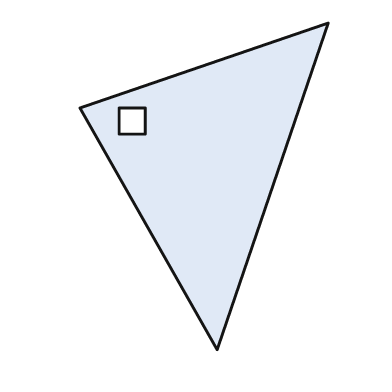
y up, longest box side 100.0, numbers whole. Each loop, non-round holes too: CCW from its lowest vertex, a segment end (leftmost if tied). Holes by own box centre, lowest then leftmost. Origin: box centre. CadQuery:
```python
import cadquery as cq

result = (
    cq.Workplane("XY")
    .moveTo(4.0, -50.0)
    .lineTo(38.0, 50.0)
    .lineTo(-38.0, 24.0)
    .close()
    .moveTo(-26.0, 16.0)
    .lineTo(-18.0, 16.0)
    .lineTo(-18.0, 24.0)
    .lineTo(-26.0, 24.0)
    .close()
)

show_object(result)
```